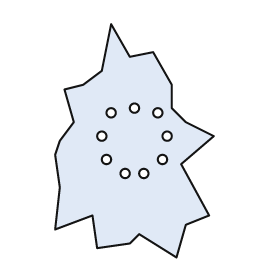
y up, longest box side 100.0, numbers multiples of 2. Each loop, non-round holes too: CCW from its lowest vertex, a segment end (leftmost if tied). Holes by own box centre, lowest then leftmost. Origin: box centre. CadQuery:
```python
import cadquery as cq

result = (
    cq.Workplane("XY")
    .moveTo(18.0, -50.0)
    .lineTo(22.0, -36.0)
    .lineTo(32.0, -32.0)
    .lineTo(20.0, -10.0)
    .lineTo(34.0, 2.0)
    .lineTo(22.0, 8.0)
    .lineTo(16.0, 14.0)
    .lineTo(16.0, 24.0)
    .lineTo(8.0, 38.0)
    .lineTo(-2.0, 36.0)
    .lineTo(-10.0, 50.0)
    .lineTo(-14.0, 30.0)
    .lineTo(-22.0, 24.0)
    .lineTo(-30.0, 22.0)
    .lineTo(-26.0, 8.0)
    .lineTo(-32.0, 0.0)
    .lineTo(-34.0, -6.0)
    .lineTo(-32.0, -20.0)
    .lineTo(-34.0, -38.0)
    .lineTo(-18.0, -32.0)
    .lineTo(-16.0, -46.0)
    .lineTo(-2.0, -44.0)
    .lineTo(2.0, -40.0)
    .close()
    .moveTo(-4.0, -14.0)
    .circle(2.0)
    .moveTo(4.0, -14.0)
    .circle(2.0)
    .moveTo(-12.0, -8.0)
    .circle(2.0)
    .moveTo(12.0, -8.0)
    .circle(2.0)
    .moveTo(-14.0, 2.0)
    .circle(2.0)
    .moveTo(14.0, 2.0)
    .circle(2.0)
    .moveTo(-10.0, 12.0)
    .circle(2.0)
    .moveTo(10.0, 12.0)
    .circle(2.0)
    .moveTo(0.0, 14.0)
    .circle(2.0)
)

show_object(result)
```